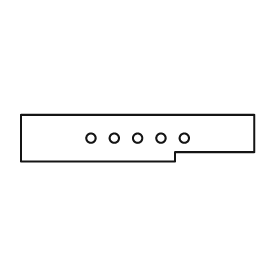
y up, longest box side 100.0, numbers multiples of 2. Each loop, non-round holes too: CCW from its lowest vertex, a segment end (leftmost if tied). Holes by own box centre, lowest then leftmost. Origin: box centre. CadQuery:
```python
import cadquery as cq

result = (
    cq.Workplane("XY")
    .moveTo(-50.0, -10.0)
    .lineTo(16.0, -10.0)
    .lineTo(16.0, -6.0)
    .lineTo(50.0, -6.0)
    .lineTo(50.0, 10.0)
    .lineTo(-50.0, 10.0)
    .close()
    .moveTo(-20.0, 0.0)
    .circle(2.0)
    .moveTo(-10.0, 0.0)
    .circle(2.0)
    .moveTo(0.0, 0.0)
    .circle(2.0)
    .moveTo(10.0, 0.0)
    .circle(2.0)
    .moveTo(20.0, 0.0)
    .circle(2.0)
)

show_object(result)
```